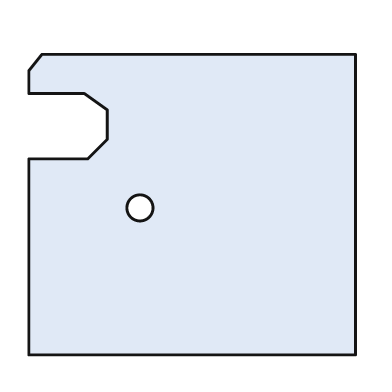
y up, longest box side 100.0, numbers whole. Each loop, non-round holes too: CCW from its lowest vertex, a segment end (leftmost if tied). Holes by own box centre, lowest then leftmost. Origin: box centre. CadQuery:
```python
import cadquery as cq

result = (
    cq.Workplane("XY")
    .moveTo(-50.0, -46.0)
    .lineTo(50.0, -46.0)
    .lineTo(50.0, 46.0)
    .lineTo(-46.0, 46.0)
    .lineTo(-50.0, 41.0)
    .lineTo(-50.0, 34.0)
    .lineTo(-33.0, 34.0)
    .lineTo(-26.0, 29.0)
    .lineTo(-26.0, 20.0)
    .lineTo(-32.0, 14.0)
    .lineTo(-50.0, 14.0)
    .close()
    .moveTo(-16.0, -1.0)
    .circle(4.0)
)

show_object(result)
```